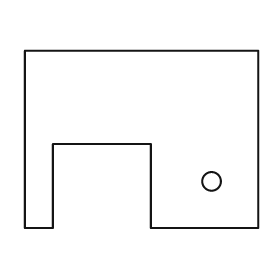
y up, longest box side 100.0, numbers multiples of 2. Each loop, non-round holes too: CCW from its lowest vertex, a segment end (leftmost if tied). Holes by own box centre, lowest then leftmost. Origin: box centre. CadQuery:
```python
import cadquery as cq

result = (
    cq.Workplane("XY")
    .moveTo(-50.0, -38.0)
    .lineTo(-38.0, -38.0)
    .lineTo(-38.0, -2.0)
    .lineTo(4.0, -2.0)
    .lineTo(4.0, -38.0)
    .lineTo(50.0, -38.0)
    .lineTo(50.0, 38.0)
    .lineTo(-50.0, 38.0)
    .close()
    .moveTo(30.0, -18.0)
    .circle(4.0)
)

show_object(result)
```